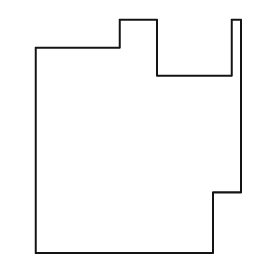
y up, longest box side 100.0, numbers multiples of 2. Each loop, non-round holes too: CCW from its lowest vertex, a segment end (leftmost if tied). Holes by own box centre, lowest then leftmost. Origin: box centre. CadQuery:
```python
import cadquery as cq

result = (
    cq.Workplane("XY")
    .moveTo(-44.0, -50.0)
    .lineTo(32.0, -50.0)
    .lineTo(32.0, -24.0)
    .lineTo(44.0, -24.0)
    .lineTo(44.0, 50.0)
    .lineTo(40.0, 50.0)
    .lineTo(40.0, 26.0)
    .lineTo(8.0, 26.0)
    .lineTo(8.0, 50.0)
    .lineTo(-8.0, 50.0)
    .lineTo(-8.0, 38.0)
    .lineTo(-44.0, 38.0)
    .close()
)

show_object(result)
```